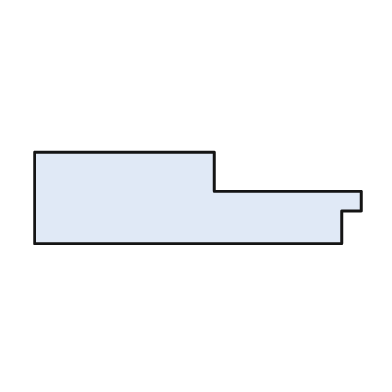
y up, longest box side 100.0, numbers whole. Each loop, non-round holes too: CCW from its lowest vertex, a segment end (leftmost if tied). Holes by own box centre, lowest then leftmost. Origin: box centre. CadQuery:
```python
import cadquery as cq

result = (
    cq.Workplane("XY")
    .moveTo(-50.0, -14.0)
    .lineTo(44.0, -14.0)
    .lineTo(44.0, -4.0)
    .lineTo(50.0, -4.0)
    .lineTo(50.0, 2.0)
    .lineTo(5.0, 2.0)
    .lineTo(5.0, 14.0)
    .lineTo(-50.0, 14.0)
    .close()
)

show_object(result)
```